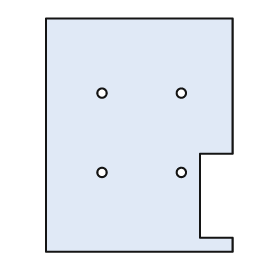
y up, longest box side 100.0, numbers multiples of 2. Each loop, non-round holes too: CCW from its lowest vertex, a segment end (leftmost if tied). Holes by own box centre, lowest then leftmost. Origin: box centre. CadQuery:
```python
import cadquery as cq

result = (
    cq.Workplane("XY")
    .moveTo(-40.0, -50.0)
    .lineTo(40.0, -50.0)
    .lineTo(40.0, -44.0)
    .lineTo(26.0, -44.0)
    .lineTo(26.0, -8.0)
    .lineTo(40.0, -8.0)
    .lineTo(40.0, 50.0)
    .lineTo(-40.0, 50.0)
    .close()
    .moveTo(-16.0, -16.0)
    .circle(2.0)
    .moveTo(18.0, -16.0)
    .circle(2.0)
    .moveTo(-16.0, 18.0)
    .circle(2.0)
    .moveTo(18.0, 18.0)
    .circle(2.0)
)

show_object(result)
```